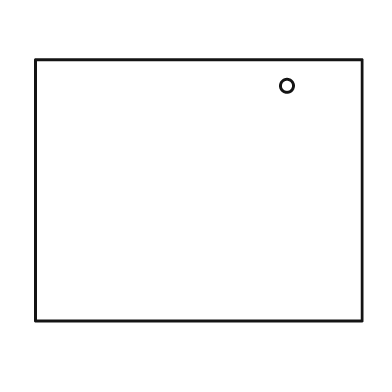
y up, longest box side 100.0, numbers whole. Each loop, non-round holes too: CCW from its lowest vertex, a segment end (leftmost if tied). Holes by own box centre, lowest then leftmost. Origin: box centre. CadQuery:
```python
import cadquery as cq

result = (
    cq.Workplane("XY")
    .moveTo(-50.0, -40.0)
    .lineTo(50.0, -40.0)
    .lineTo(50.0, 40.0)
    .lineTo(-50.0, 40.0)
    .close()
    .moveTo(27.0, 32.0)
    .circle(2.0)
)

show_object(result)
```